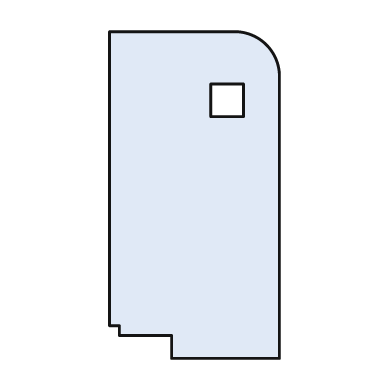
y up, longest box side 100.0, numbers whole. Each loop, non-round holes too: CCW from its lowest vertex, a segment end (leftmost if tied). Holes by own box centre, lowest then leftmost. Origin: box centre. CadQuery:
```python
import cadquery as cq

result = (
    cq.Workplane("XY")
    .moveTo(-7.0, -50.0)
    .lineTo(26.0, -50.0)
    .lineTo(26.0, 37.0)
    .threePointArc((22.0, 46.0), (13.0, 50.0))
    .lineTo(-26.0, 50.0)
    .lineTo(-26.0, -40.0)
    .lineTo(-23.0, -40.0)
    .lineTo(-23.0, -43.0)
    .lineTo(-7.0, -43.0)
    .close()
    .moveTo(5.0, 24.0)
    .lineTo(15.0, 24.0)
    .lineTo(15.0, 34.0)
    .lineTo(5.0, 34.0)
    .close()
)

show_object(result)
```